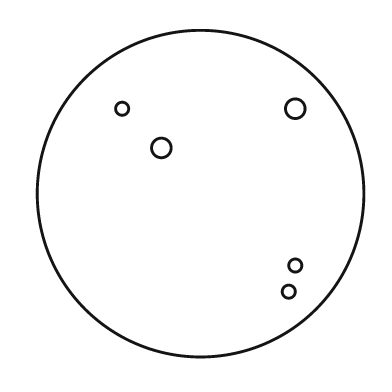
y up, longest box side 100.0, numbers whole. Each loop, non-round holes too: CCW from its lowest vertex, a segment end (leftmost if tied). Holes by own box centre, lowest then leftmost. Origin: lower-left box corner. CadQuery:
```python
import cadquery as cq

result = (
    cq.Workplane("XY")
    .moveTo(50.0, 50.0)
    .circle(50.0)
    .moveTo(77.0, 20.0)
    .circle(2.0)
    .moveTo(79.0, 28.0)
    .circle(2.0)
    .moveTo(38.0, 64.0)
    .circle(3.0)
    .moveTo(26.0, 76.0)
    .circle(2.0)
    .moveTo(79.0, 76.0)
    .circle(3.0)
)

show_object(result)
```